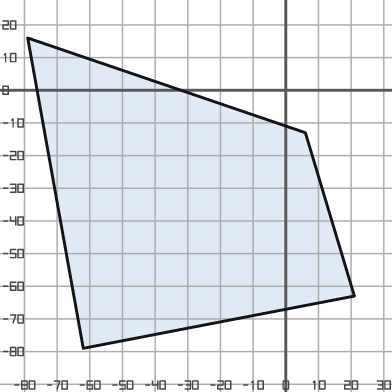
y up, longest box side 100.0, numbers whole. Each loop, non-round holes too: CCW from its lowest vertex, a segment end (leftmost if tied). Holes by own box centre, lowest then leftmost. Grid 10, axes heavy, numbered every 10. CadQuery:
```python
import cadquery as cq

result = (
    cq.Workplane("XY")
    .moveTo(-62.0, -79.0)
    .lineTo(21.0, -63.0)
    .lineTo(6.0, -13.0)
    .lineTo(-79.0, 16.0)
    .close()
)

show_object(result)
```